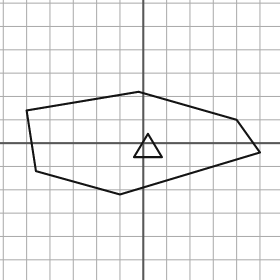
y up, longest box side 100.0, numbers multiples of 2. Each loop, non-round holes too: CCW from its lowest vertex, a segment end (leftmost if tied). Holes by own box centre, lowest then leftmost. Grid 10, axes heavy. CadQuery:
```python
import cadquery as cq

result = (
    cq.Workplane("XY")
    .moveTo(-10.0, -22.0)
    .lineTo(50.0, -4.0)
    .lineTo(40.0, 10.0)
    .lineTo(-2.0, 22.0)
    .lineTo(-50.0, 14.0)
    .lineTo(-46.0, -12.0)
    .close()
    .moveTo(-4.0, -6.0)
    .lineTo(8.0, -6.0)
    .lineTo(2.0, 4.0)
    .close()
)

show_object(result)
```